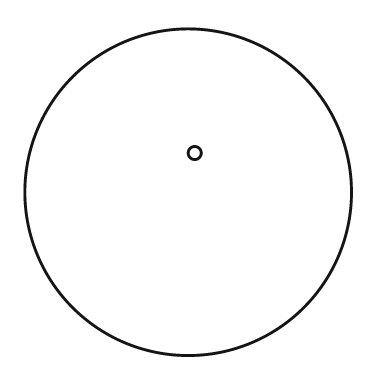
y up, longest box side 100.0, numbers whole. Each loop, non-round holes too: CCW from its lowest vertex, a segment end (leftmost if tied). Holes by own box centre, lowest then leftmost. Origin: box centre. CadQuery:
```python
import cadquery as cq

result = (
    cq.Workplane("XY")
    .moveTo(0.0, 0.0)
    .circle(50.0)
    .moveTo(2.0, 12.0)
    .circle(2.0)
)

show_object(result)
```